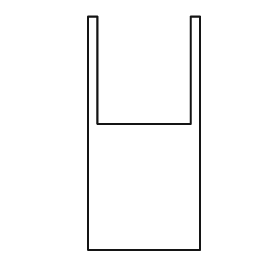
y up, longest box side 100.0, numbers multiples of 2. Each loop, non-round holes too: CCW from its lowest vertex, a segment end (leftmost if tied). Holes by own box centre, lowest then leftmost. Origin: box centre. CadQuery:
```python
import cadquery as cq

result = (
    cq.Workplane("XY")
    .moveTo(-24.0, -50.0)
    .lineTo(24.0, -50.0)
    .lineTo(24.0, 50.0)
    .lineTo(20.0, 50.0)
    .lineTo(20.0, 4.0)
    .lineTo(-20.0, 4.0)
    .lineTo(-20.0, 50.0)
    .lineTo(-24.0, 50.0)
    .close()
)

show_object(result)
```